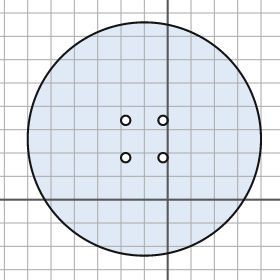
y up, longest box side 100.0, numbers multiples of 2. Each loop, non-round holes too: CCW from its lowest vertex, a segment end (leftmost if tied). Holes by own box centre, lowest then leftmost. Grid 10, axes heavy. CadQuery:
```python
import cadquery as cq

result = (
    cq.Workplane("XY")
    .moveTo(-10.0, 26.0)
    .circle(50.0)
    .moveTo(-18.0, 18.0)
    .circle(2.0)
    .moveTo(-2.0, 18.0)
    .circle(2.0)
    .moveTo(-18.0, 34.0)
    .circle(2.0)
    .moveTo(-2.0, 34.0)
    .circle(2.0)
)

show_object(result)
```